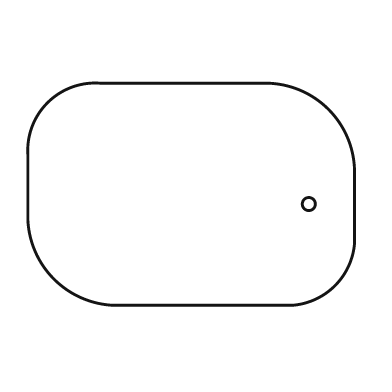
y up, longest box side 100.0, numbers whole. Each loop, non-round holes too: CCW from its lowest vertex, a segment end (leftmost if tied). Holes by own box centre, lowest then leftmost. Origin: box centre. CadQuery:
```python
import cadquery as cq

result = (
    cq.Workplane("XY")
    .moveTo(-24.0, -34.0)
    .lineTo(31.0, -34.0)
    .threePointArc((44.0, -28.0), (50.0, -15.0))
    .lineTo(50.0, 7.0)
    .threePointArc((42.0, 26.0), (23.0, 34.0))
    .lineTo(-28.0, 34.0)
    .threePointArc((-44.0, 28.0), (-50.0, 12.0))
    .lineTo(-50.0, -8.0)
    .threePointArc((-42.0, -26.0), (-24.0, -34.0))
    .close()
    .moveTo(36.0, -3.0)
    .circle(2.0)
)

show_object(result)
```